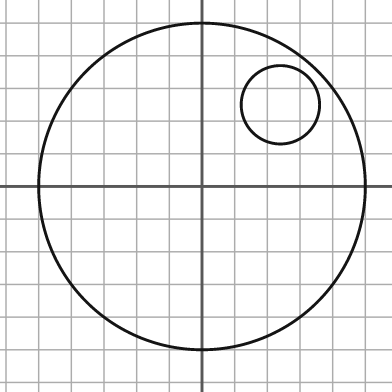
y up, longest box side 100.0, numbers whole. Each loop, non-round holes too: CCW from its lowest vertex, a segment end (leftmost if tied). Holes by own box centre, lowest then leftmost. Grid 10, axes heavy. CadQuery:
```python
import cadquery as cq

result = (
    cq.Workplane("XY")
    .moveTo(0.0, 0.0)
    .circle(50.0)
    .moveTo(24.0, 25.0)
    .circle(12.0)
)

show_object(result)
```